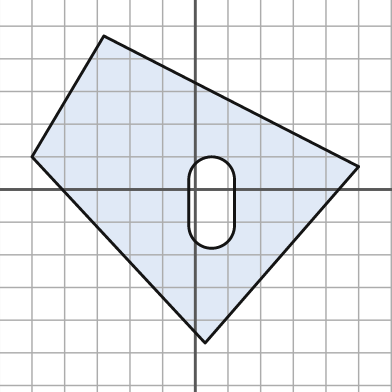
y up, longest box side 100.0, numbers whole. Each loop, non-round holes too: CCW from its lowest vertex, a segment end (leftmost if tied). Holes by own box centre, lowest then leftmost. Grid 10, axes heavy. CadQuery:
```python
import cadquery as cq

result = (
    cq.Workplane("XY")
    .moveTo(3.0, -47.0)
    .lineTo(50.0, 7.0)
    .lineTo(-28.0, 47.0)
    .lineTo(-50.0, 10.0)
    .close()
    .moveTo(-2.0, -11.0)
    .threePointArc((5.0, -18.0), (12.0, -11.0))
    .lineTo(12.0, 3.0)
    .threePointArc((5.0, 10.0), (-2.0, 3.0))
    .close()
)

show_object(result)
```